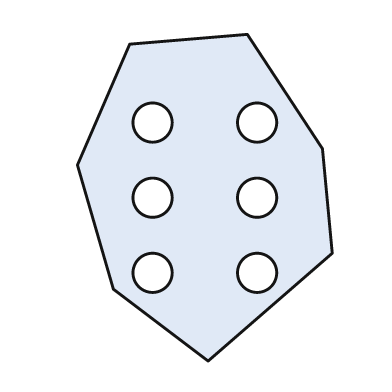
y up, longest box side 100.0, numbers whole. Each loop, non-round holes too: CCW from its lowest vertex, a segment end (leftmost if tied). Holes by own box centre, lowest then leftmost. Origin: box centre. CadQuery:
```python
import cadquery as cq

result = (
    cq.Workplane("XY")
    .moveTo(1.0, -50.0)
    .lineTo(39.0, -17.0)
    .lineTo(36.0, 15.0)
    .lineTo(13.0, 50.0)
    .lineTo(-23.0, 47.0)
    .lineTo(-39.0, 10.0)
    .lineTo(-28.0, -28.0)
    .close()
    .moveTo(-16.0, -23.0)
    .circle(6.0)
    .moveTo(16.0, -23.0)
    .circle(6.0)
    .moveTo(-16.0, 0.0)
    .circle(6.0)
    .moveTo(16.0, 0.0)
    .circle(6.0)
    .moveTo(-16.0, 23.0)
    .circle(6.0)
    .moveTo(16.0, 23.0)
    .circle(6.0)
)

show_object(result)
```